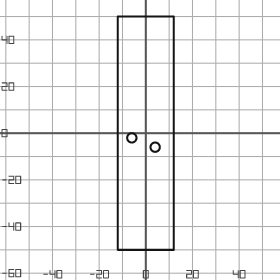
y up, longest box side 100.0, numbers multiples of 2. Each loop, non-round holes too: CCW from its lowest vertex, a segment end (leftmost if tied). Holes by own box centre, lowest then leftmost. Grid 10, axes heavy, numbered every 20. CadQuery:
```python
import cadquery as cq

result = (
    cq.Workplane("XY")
    .moveTo(-12.0, -50.0)
    .lineTo(12.0, -50.0)
    .lineTo(12.0, 50.0)
    .lineTo(-12.0, 50.0)
    .close()
    .moveTo(4.0, -6.0)
    .circle(2.0)
    .moveTo(-6.0, -2.0)
    .circle(2.0)
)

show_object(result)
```